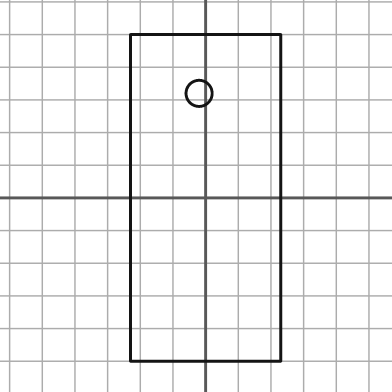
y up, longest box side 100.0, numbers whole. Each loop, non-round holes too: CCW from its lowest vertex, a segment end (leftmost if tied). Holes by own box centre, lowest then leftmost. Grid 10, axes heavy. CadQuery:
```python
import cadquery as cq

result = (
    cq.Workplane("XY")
    .moveTo(-23.0, -50.0)
    .lineTo(23.0, -50.0)
    .lineTo(23.0, 50.0)
    .lineTo(-23.0, 50.0)
    .close()
    .moveTo(-2.0, 32.0)
    .circle(4.0)
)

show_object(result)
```